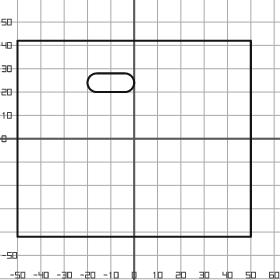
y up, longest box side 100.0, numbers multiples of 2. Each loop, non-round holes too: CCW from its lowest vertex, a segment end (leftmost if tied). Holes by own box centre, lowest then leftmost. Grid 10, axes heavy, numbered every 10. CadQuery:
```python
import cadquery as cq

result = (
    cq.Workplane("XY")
    .moveTo(-50.0, -42.0)
    .lineTo(50.0, -42.0)
    .lineTo(50.0, 42.0)
    .lineTo(-50.0, 42.0)
    .close()
    .moveTo(-16.0, 20.0)
    .lineTo(-4.0, 20.0)
    .threePointArc((0.0, 24.0), (-4.0, 28.0))
    .lineTo(-16.0, 28.0)
    .threePointArc((-20.0, 24.0), (-16.0, 20.0))
    .close()
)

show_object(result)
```